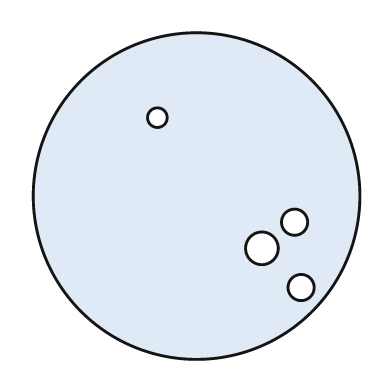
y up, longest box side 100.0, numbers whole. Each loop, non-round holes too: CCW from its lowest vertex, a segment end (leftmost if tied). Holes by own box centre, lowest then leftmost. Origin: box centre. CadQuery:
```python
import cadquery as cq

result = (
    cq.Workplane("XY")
    .moveTo(0.0, 0.0)
    .circle(50.0)
    .moveTo(32.0, -28.0)
    .circle(4.0)
    .moveTo(20.0, -16.0)
    .circle(5.0)
    .moveTo(30.0, -8.0)
    .circle(4.0)
    .moveTo(-12.0, 24.0)
    .circle(3.0)
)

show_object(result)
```